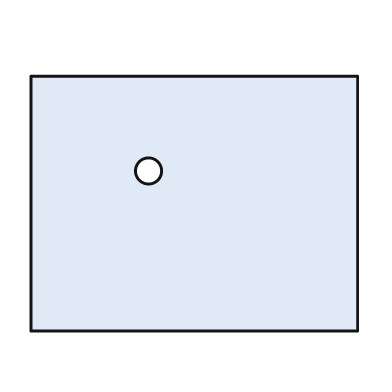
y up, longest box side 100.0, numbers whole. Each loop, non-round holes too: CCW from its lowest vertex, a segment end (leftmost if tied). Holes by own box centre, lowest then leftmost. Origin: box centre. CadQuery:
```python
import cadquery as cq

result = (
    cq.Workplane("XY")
    .moveTo(-50.0, -39.0)
    .lineTo(50.0, -39.0)
    .lineTo(50.0, 39.0)
    .lineTo(-50.0, 39.0)
    .close()
    .moveTo(-14.0, 10.0)
    .circle(4.0)
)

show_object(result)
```